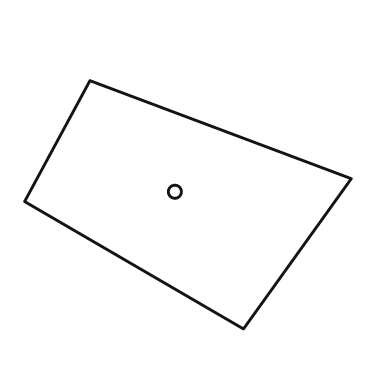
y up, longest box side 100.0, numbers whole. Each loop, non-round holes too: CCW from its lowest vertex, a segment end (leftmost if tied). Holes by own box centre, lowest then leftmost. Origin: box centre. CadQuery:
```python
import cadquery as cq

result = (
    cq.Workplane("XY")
    .moveTo(17.0, -38.0)
    .lineTo(50.0, 8.0)
    .lineTo(-30.0, 38.0)
    .lineTo(-50.0, 1.0)
    .close()
    .moveTo(-4.0, 4.0)
    .circle(2.0)
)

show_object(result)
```